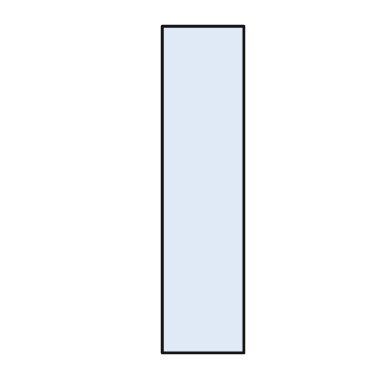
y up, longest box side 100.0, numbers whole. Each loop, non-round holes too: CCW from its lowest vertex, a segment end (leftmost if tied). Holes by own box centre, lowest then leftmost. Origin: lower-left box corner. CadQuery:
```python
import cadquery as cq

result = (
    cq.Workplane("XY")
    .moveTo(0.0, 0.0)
    .lineTo(25.0, 0.0)
    .lineTo(25.0, 100.0)
    .lineTo(0.0, 100.0)
    .close()
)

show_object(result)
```